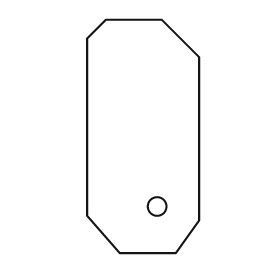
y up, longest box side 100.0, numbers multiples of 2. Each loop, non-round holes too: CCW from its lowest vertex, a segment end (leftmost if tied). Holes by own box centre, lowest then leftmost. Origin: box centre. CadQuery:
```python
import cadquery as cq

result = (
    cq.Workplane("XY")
    .moveTo(-10.0, -50.0)
    .lineTo(14.0, -50.0)
    .lineTo(24.0, -36.0)
    .lineTo(24.0, 34.0)
    .lineTo(8.0, 50.0)
    .lineTo(-16.0, 50.0)
    .lineTo(-24.0, 42.0)
    .lineTo(-24.0, -34.0)
    .close()
    .moveTo(6.0, -30.0)
    .circle(4.0)
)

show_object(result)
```